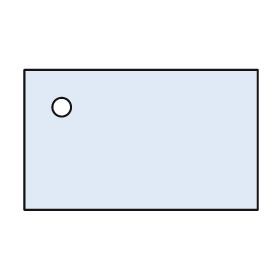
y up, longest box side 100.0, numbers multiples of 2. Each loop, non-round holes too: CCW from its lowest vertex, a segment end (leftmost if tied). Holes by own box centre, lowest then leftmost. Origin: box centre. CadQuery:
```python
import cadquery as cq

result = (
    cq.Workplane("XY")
    .moveTo(-50.0, -30.0)
    .lineTo(50.0, -30.0)
    .lineTo(50.0, 30.0)
    .lineTo(-50.0, 30.0)
    .close()
    .moveTo(-34.0, 14.0)
    .circle(4.0)
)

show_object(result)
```